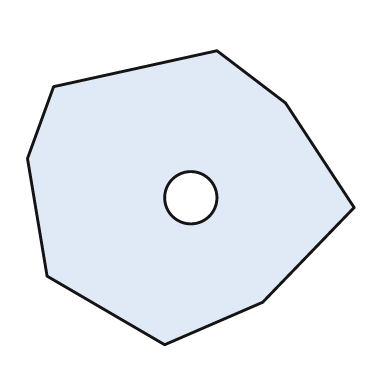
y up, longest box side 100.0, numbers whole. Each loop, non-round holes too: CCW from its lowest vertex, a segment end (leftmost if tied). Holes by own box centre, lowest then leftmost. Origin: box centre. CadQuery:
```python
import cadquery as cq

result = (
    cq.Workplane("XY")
    .moveTo(-8.0, -45.0)
    .lineTo(22.0, -32.0)
    .lineTo(50.0, -3.0)
    .lineTo(29.0, 29.0)
    .lineTo(8.0, 45.0)
    .lineTo(-42.0, 34.0)
    .lineTo(-50.0, 12.0)
    .lineTo(-44.0, -24.0)
    .close()
    .moveTo(0.0, 0.0)
    .circle(8.0)
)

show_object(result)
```